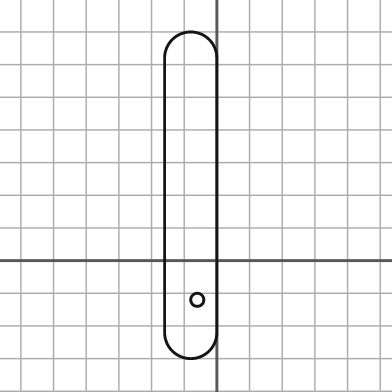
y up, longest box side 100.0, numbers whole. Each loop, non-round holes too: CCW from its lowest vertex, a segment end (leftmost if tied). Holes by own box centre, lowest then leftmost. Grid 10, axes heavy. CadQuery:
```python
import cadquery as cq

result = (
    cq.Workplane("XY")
    .moveTo(-16.0, -22.0)
    .threePointArc((-8.0, -30.0), (0.0, -22.0))
    .lineTo(0.0, 62.0)
    .threePointArc((-8.0, 70.0), (-16.0, 62.0))
    .close()
    .moveTo(-6.0, -12.0)
    .circle(2.0)
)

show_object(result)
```